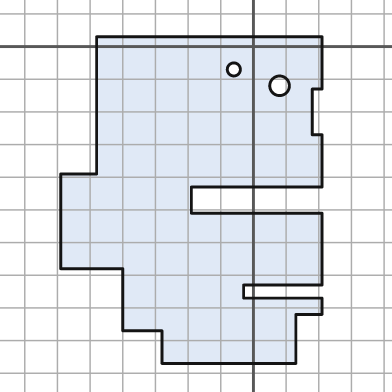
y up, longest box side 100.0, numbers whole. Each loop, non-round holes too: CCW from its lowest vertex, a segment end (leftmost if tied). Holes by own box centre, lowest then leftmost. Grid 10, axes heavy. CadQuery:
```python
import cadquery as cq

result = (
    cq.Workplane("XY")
    .moveTo(-28.0, -97.0)
    .lineTo(13.0, -97.0)
    .lineTo(13.0, -82.0)
    .lineTo(21.0, -82.0)
    .lineTo(21.0, -77.0)
    .lineTo(-3.0, -77.0)
    .lineTo(-3.0, -73.0)
    .lineTo(21.0, -73.0)
    .lineTo(21.0, -51.0)
    .lineTo(-19.0, -51.0)
    .lineTo(-19.0, -43.0)
    .lineTo(21.0, -43.0)
    .lineTo(21.0, -27.0)
    .lineTo(18.0, -27.0)
    .lineTo(18.0, -13.0)
    .lineTo(21.0, -13.0)
    .lineTo(21.0, 3.0)
    .lineTo(-48.0, 3.0)
    .lineTo(-48.0, -39.0)
    .lineTo(-59.0, -39.0)
    .lineTo(-59.0, -68.0)
    .lineTo(-40.0, -68.0)
    .lineTo(-40.0, -87.0)
    .lineTo(-28.0, -87.0)
    .close()
    .moveTo(8.0, -12.0)
    .circle(3.0)
    .moveTo(-6.0, -7.0)
    .circle(2.0)
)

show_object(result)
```